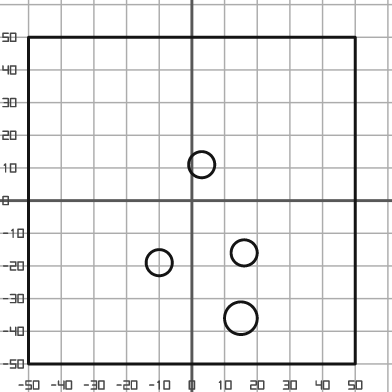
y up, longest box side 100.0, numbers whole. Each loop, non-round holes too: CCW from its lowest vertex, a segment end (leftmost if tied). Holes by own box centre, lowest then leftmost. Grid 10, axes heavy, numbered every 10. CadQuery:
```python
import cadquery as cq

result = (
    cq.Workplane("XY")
    .moveTo(-50.0, -50.0)
    .lineTo(50.0, -50.0)
    .lineTo(50.0, 50.0)
    .lineTo(-50.0, 50.0)
    .close()
    .moveTo(15.0, -36.0)
    .circle(5.0)
    .moveTo(-10.0, -19.0)
    .circle(4.0)
    .moveTo(16.0, -16.0)
    .circle(4.0)
    .moveTo(3.0, 11.0)
    .circle(4.0)
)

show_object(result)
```